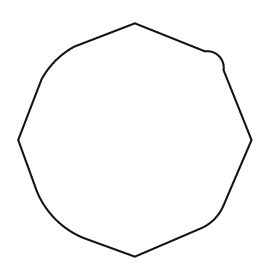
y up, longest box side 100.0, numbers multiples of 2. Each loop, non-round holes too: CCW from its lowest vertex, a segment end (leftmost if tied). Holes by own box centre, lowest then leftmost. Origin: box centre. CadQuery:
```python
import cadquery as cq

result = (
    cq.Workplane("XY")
    .moveTo(0.0, -50.0)
    .lineTo(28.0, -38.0)
    .threePointArc((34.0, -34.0), (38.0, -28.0))
    .lineTo(50.0, 0.0)
    .lineTo(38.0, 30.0)
    .threePointArc((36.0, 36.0), (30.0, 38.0))
    .lineTo(0.0, 50.0)
    .lineTo(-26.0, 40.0)
    .threePointArc((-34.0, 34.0), (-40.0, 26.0))
    .lineTo(-50.0, 0.0)
    .lineTo(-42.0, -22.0)
    .threePointArc((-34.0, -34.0), (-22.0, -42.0))
    .close()
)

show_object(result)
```